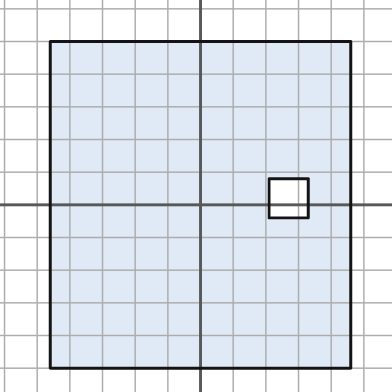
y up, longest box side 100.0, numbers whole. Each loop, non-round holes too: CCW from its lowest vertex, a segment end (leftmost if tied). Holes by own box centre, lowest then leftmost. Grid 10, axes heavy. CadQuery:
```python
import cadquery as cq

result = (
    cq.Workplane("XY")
    .moveTo(-46.0, -50.0)
    .lineTo(46.0, -50.0)
    .lineTo(46.0, 50.0)
    .lineTo(-46.0, 50.0)
    .close()
    .moveTo(21.0, -4.0)
    .lineTo(33.0, -4.0)
    .lineTo(33.0, 8.0)
    .lineTo(21.0, 8.0)
    .close()
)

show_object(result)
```